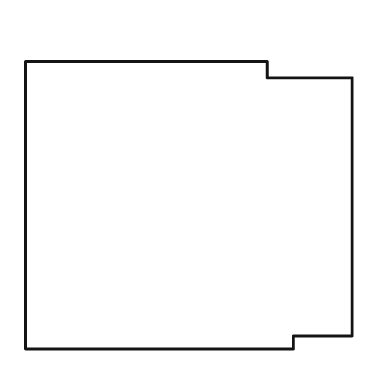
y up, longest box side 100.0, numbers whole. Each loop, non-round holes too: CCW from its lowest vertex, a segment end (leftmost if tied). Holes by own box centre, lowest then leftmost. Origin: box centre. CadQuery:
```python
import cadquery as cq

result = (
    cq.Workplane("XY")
    .moveTo(-50.0, -44.0)
    .lineTo(32.0, -44.0)
    .lineTo(32.0, -40.0)
    .lineTo(50.0, -40.0)
    .lineTo(50.0, 39.0)
    .lineTo(24.0, 39.0)
    .lineTo(24.0, 44.0)
    .lineTo(-50.0, 44.0)
    .close()
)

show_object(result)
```